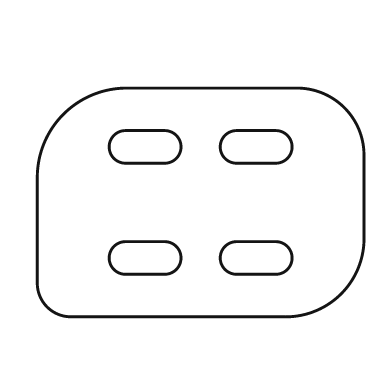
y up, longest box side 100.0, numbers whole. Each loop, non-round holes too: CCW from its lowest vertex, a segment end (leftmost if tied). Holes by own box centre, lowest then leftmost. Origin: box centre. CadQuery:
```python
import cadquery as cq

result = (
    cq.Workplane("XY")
    .moveTo(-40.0, -35.0)
    .lineTo(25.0, -35.0)
    .threePointArc((43.0, -28.0), (50.0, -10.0))
    .lineTo(50.0, 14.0)
    .threePointArc((44.0, 29.0), (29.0, 35.0))
    .lineTo(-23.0, 35.0)
    .threePointArc((-42.0, 27.0), (-50.0, 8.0))
    .lineTo(-50.0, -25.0)
    .threePointArc((-47.0, -32.0), (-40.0, -35.0))
    .close()
    .moveTo(-23.0, -22.0)
    .lineTo(-11.0, -22.0)
    .threePointArc((-6.0, -17.0), (-11.0, -12.0))
    .lineTo(-23.0, -12.0)
    .threePointArc((-28.0, -17.0), (-23.0, -22.0))
    .close()
    .moveTo(11.0, -22.0)
    .lineTo(23.0, -22.0)
    .threePointArc((28.0, -17.0), (23.0, -12.0))
    .lineTo(11.0, -12.0)
    .threePointArc((6.0, -17.0), (11.0, -22.0))
    .close()
    .moveTo(-23.0, 12.0)
    .lineTo(-11.0, 12.0)
    .threePointArc((-6.0, 17.0), (-11.0, 22.0))
    .lineTo(-23.0, 22.0)
    .threePointArc((-28.0, 17.0), (-23.0, 12.0))
    .close()
    .moveTo(11.0, 12.0)
    .lineTo(23.0, 12.0)
    .threePointArc((28.0, 17.0), (23.0, 22.0))
    .lineTo(11.0, 22.0)
    .threePointArc((6.0, 17.0), (11.0, 12.0))
    .close()
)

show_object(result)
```